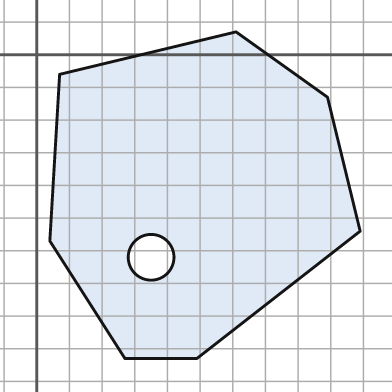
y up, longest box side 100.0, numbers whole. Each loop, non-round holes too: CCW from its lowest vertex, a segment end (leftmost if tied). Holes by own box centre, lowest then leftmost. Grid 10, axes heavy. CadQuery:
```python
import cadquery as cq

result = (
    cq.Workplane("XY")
    .moveTo(27.0, -93.0)
    .lineTo(49.0, -93.0)
    .lineTo(99.0, -54.0)
    .lineTo(89.0, -13.0)
    .lineTo(61.0, 7.0)
    .lineTo(7.0, -6.0)
    .lineTo(4.0, -57.0)
    .close()
    .moveTo(35.0, -62.0)
    .circle(7.0)
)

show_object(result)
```